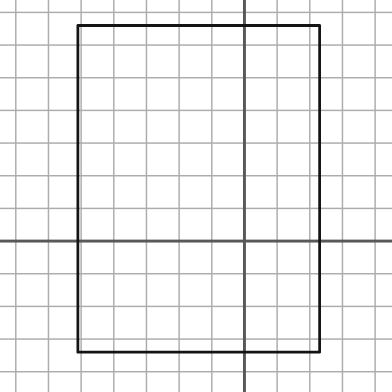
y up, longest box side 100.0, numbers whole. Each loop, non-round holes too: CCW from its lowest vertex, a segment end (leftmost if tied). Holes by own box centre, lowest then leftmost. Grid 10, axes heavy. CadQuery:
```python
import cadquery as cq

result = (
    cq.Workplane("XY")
    .moveTo(-51.0, -34.0)
    .lineTo(23.0, -34.0)
    .lineTo(23.0, 66.0)
    .lineTo(-51.0, 66.0)
    .close()
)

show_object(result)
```